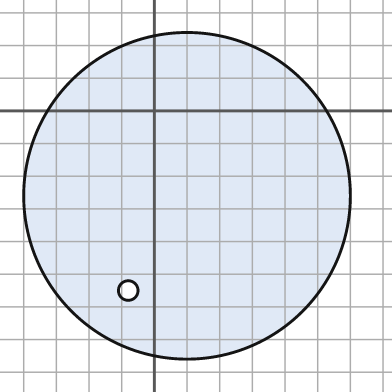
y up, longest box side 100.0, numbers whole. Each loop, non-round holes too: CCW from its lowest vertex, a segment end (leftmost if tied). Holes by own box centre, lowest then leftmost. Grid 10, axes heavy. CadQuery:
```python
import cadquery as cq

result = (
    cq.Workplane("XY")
    .moveTo(10.0, -26.0)
    .circle(50.0)
    .moveTo(-8.0, -55.0)
    .circle(3.0)
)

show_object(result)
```